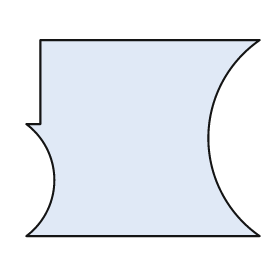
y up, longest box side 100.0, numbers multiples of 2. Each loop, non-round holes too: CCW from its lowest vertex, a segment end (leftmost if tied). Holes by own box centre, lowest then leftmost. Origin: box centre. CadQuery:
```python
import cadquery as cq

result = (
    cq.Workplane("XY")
    .moveTo(-50.0, -42.0)
    .lineTo(50.0, -42.0)
    .threePointArc((28.0, 0.0), (50.0, 42.0))
    .lineTo(-44.0, 42.0)
    .lineTo(-44.0, 6.0)
    .lineTo(-50.0, 6.0)
    .threePointArc((-38.0, -18.0), (-50.0, -42.0))
    .close()
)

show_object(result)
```